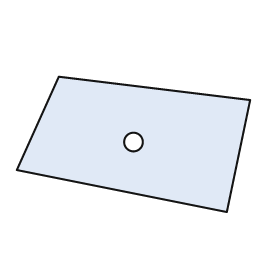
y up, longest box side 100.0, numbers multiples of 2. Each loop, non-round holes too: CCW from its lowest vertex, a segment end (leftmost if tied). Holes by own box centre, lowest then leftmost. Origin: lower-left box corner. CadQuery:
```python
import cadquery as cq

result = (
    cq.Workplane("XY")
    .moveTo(90.0, 0.0)
    .lineTo(100.0, 48.0)
    .lineTo(18.0, 58.0)
    .lineTo(0.0, 18.0)
    .close()
    .moveTo(50.0, 30.0)
    .circle(4.0)
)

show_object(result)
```